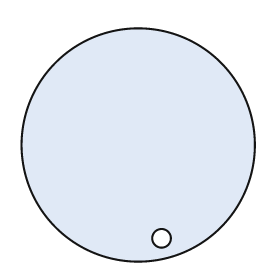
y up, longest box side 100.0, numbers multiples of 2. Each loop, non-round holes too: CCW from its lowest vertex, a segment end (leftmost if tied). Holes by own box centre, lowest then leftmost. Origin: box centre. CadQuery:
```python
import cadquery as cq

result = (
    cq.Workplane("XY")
    .moveTo(0.0, 0.0)
    .circle(50.0)
    .moveTo(10.0, -40.0)
    .circle(4.0)
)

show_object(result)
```